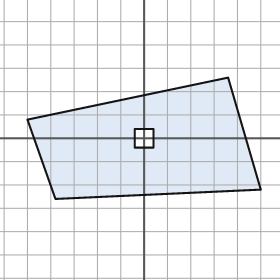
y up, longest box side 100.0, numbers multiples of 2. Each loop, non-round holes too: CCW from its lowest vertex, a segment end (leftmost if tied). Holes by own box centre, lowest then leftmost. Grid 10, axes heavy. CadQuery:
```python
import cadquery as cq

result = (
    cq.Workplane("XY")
    .moveTo(-38.0, -26.0)
    .lineTo(50.0, -22.0)
    .lineTo(36.0, 26.0)
    .lineTo(-50.0, 8.0)
    .close()
    .moveTo(-4.0, -4.0)
    .lineTo(4.0, -4.0)
    .lineTo(4.0, 4.0)
    .lineTo(-4.0, 4.0)
    .close()
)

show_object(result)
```